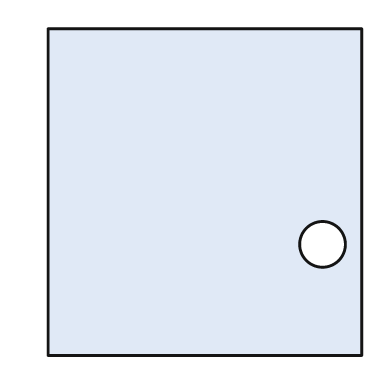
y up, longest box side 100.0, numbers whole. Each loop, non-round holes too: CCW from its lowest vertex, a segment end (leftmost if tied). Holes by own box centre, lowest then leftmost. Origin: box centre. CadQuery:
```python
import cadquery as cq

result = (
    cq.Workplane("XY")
    .moveTo(-48.0, -50.0)
    .lineTo(48.0, -50.0)
    .lineTo(48.0, 50.0)
    .lineTo(-48.0, 50.0)
    .close()
    .moveTo(36.0, -16.0)
    .circle(7.0)
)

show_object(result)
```